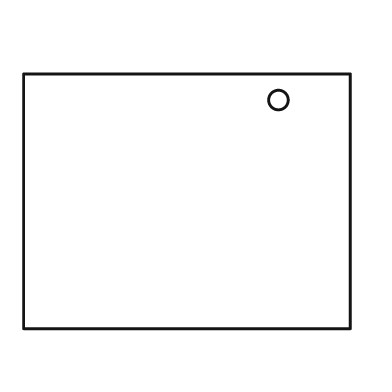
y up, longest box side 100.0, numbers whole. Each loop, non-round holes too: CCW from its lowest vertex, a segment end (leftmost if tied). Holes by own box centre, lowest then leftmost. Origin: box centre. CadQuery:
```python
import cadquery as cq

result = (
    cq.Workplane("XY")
    .moveTo(-50.0, -39.0)
    .lineTo(50.0, -39.0)
    .lineTo(50.0, 39.0)
    .lineTo(-50.0, 39.0)
    .close()
    .moveTo(28.0, 31.0)
    .circle(3.0)
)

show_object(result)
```